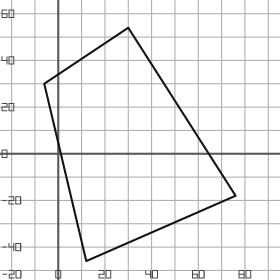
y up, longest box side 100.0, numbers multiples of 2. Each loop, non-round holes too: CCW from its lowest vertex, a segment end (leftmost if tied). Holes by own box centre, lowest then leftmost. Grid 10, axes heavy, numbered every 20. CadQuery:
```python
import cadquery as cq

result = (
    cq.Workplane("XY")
    .moveTo(12.0, -46.0)
    .lineTo(76.0, -18.0)
    .lineTo(30.0, 54.0)
    .lineTo(-6.0, 30.0)
    .close()
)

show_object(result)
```